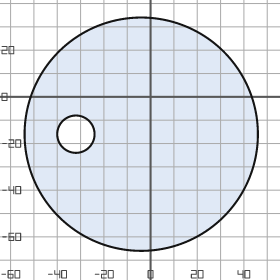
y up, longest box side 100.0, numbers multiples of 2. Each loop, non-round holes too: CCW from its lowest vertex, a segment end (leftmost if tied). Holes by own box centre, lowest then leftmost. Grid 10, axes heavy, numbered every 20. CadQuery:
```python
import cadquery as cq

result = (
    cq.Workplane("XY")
    .moveTo(-4.0, -16.0)
    .circle(50.0)
    .moveTo(-32.0, -16.0)
    .circle(8.0)
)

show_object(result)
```